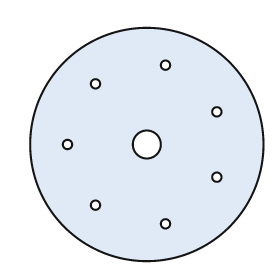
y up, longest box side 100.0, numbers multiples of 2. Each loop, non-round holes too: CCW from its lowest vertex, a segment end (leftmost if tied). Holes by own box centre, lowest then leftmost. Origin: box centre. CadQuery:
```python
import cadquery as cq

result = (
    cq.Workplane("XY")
    .moveTo(0.0, 0.0)
    .circle(50.0)
    .moveTo(8.0, -34.0)
    .circle(2.0)
    .moveTo(-22.0, -26.0)
    .circle(2.0)
    .moveTo(30.0, -14.0)
    .circle(2.0)
    .moveTo(-34.0, 0.0)
    .circle(2.0)
    .moveTo(0.0, 0.0)
    .circle(6.0)
    .moveTo(30.0, 14.0)
    .circle(2.0)
    .moveTo(-22.0, 26.0)
    .circle(2.0)
    .moveTo(8.0, 34.0)
    .circle(2.0)
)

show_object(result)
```